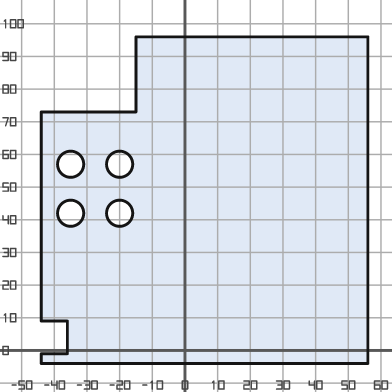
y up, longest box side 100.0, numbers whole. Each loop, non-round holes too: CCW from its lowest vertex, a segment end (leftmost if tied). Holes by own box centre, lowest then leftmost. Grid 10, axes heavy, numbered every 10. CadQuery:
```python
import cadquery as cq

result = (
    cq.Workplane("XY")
    .moveTo(-44.0, -4.0)
    .lineTo(56.0, -4.0)
    .lineTo(56.0, 96.0)
    .lineTo(-15.0, 96.0)
    .lineTo(-15.0, 73.0)
    .lineTo(-44.0, 73.0)
    .lineTo(-44.0, 9.0)
    .lineTo(-36.0, 9.0)
    .lineTo(-36.0, -1.0)
    .lineTo(-44.0, -1.0)
    .close()
    .moveTo(-35.0, 42.0)
    .circle(4.0)
    .moveTo(-20.0, 42.0)
    .circle(4.0)
    .moveTo(-35.0, 57.0)
    .circle(4.0)
    .moveTo(-20.0, 57.0)
    .circle(4.0)
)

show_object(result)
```